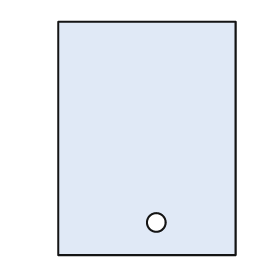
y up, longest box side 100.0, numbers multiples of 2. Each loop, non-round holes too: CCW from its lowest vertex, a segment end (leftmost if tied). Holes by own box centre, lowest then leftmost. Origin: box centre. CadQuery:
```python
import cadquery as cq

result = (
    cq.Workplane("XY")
    .moveTo(-38.0, -50.0)
    .lineTo(38.0, -50.0)
    .lineTo(38.0, 50.0)
    .lineTo(-38.0, 50.0)
    .close()
    .moveTo(4.0, -36.0)
    .circle(4.0)
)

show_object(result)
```